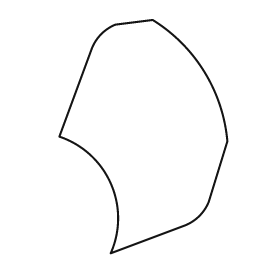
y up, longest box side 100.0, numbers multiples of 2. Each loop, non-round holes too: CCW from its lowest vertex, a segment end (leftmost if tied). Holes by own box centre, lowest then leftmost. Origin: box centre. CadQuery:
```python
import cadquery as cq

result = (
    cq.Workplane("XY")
    .moveTo(-14.0, -50.0)
    .lineTo(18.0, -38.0)
    .threePointArc((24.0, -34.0), (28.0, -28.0))
    .lineTo(36.0, -2.0)
    .threePointArc((26.0, 28.0), (4.0, 50.0))
    .lineTo(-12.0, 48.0)
    .threePointArc((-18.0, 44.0), (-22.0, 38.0))
    .lineTo(-36.0, 0.0)
    .threePointArc((-14.0, -20.0), (-14.0, -50.0))
    .close()
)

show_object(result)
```